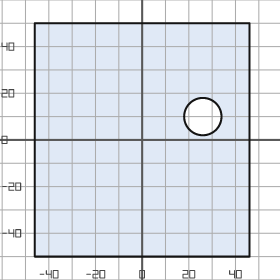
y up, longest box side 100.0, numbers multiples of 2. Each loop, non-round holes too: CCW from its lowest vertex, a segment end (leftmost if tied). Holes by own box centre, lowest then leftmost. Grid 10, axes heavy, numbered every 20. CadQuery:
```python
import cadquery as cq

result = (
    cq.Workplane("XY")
    .moveTo(-46.0, -50.0)
    .lineTo(46.0, -50.0)
    .lineTo(46.0, 50.0)
    .lineTo(-46.0, 50.0)
    .close()
    .moveTo(26.0, 10.0)
    .circle(8.0)
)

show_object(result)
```